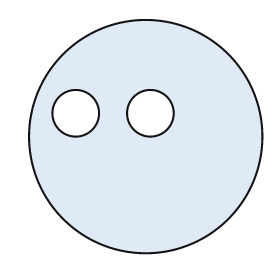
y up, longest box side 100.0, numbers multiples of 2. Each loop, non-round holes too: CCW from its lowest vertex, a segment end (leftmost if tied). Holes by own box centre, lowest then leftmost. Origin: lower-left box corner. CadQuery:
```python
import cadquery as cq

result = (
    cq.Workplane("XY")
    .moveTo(50.0, 50.0)
    .circle(50.0)
    .moveTo(20.0, 60.0)
    .circle(10.0)
    .moveTo(52.0, 60.0)
    .circle(10.0)
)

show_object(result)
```